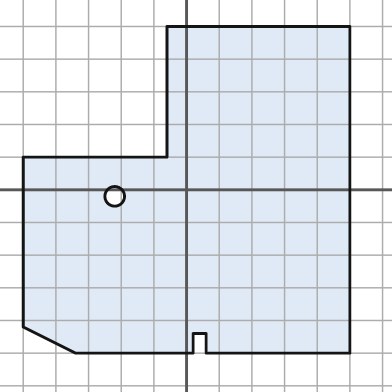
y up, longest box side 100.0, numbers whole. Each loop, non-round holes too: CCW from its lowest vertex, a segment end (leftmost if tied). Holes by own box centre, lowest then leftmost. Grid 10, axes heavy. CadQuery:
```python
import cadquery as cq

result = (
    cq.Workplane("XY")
    .moveTo(-34.0, -50.0)
    .lineTo(2.0, -50.0)
    .lineTo(2.0, -44.0)
    .lineTo(6.0, -44.0)
    .lineTo(6.0, -50.0)
    .lineTo(50.0, -50.0)
    .lineTo(50.0, 50.0)
    .lineTo(-6.0, 50.0)
    .lineTo(-6.0, 10.0)
    .lineTo(-50.0, 10.0)
    .lineTo(-50.0, -42.0)
    .close()
    .moveTo(-22.0, -2.0)
    .circle(3.0)
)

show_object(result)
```